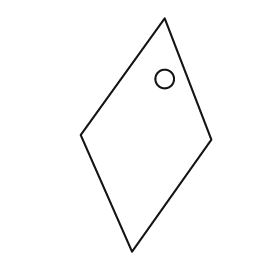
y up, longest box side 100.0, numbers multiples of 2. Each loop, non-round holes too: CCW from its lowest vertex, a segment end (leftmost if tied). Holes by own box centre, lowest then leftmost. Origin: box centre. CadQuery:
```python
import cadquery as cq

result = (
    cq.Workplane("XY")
    .moveTo(-6.0, -50.0)
    .lineTo(28.0, -2.0)
    .lineTo(8.0, 50.0)
    .lineTo(-28.0, 0.0)
    .close()
    .moveTo(8.0, 24.0)
    .circle(4.0)
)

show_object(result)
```